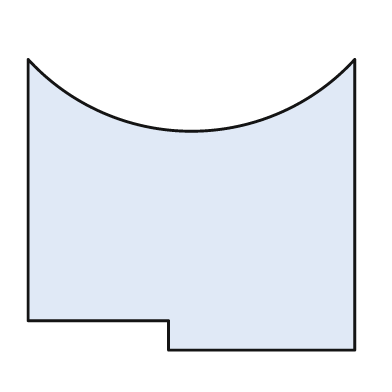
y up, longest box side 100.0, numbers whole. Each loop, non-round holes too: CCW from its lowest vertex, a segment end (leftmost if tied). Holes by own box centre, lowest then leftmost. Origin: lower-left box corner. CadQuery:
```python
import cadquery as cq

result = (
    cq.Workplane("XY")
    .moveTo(43.0, 0.0)
    .lineTo(100.0, 0.0)
    .lineTo(100.0, 89.0)
    .threePointArc((50.0, 67.0), (0.0, 89.0))
    .lineTo(0.0, 9.0)
    .lineTo(43.0, 9.0)
    .close()
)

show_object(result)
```